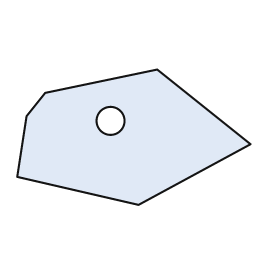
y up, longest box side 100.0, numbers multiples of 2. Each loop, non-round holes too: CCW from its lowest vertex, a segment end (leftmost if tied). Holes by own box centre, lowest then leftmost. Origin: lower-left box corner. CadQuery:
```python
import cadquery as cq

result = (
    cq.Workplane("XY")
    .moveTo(52.0, 0.0)
    .lineTo(100.0, 26.0)
    .lineTo(60.0, 58.0)
    .lineTo(12.0, 48.0)
    .lineTo(4.0, 38.0)
    .lineTo(0.0, 12.0)
    .close()
    .moveTo(40.0, 36.0)
    .circle(6.0)
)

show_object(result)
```